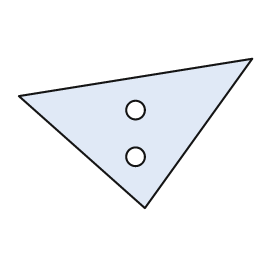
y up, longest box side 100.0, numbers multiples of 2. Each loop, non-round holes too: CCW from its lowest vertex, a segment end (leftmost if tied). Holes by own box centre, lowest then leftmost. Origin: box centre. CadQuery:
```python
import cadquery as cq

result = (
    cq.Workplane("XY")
    .moveTo(4.0, -32.0)
    .lineTo(50.0, 32.0)
    .lineTo(-50.0, 16.0)
    .close()
    .moveTo(0.0, -10.0)
    .circle(4.0)
    .moveTo(0.0, 10.0)
    .circle(4.0)
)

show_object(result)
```